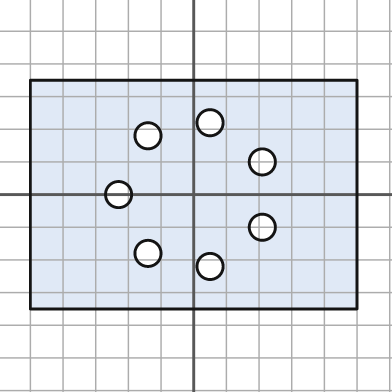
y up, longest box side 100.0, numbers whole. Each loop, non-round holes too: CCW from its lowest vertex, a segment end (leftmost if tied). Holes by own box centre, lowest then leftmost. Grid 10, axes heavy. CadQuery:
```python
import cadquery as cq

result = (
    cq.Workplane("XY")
    .moveTo(-50.0, -35.0)
    .lineTo(50.0, -35.0)
    .lineTo(50.0, 35.0)
    .lineTo(-50.0, 35.0)
    .close()
    .moveTo(5.0, -22.0)
    .circle(4.0)
    .moveTo(-14.0, -18.0)
    .circle(4.0)
    .moveTo(21.0, -10.0)
    .circle(4.0)
    .moveTo(-23.0, 0.0)
    .circle(4.0)
    .moveTo(21.0, 10.0)
    .circle(4.0)
    .moveTo(-14.0, 18.0)
    .circle(4.0)
    .moveTo(5.0, 22.0)
    .circle(4.0)
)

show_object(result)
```